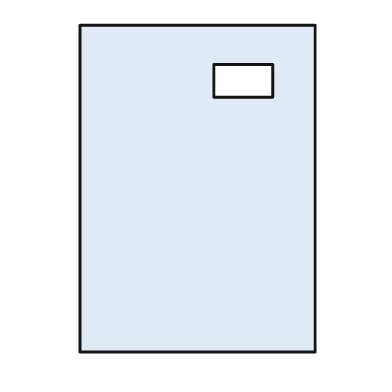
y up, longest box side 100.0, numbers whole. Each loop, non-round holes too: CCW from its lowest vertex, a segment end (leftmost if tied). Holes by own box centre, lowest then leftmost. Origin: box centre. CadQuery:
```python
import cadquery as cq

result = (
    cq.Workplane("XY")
    .moveTo(-36.0, -50.0)
    .lineTo(36.0, -50.0)
    .lineTo(36.0, 50.0)
    .lineTo(-36.0, 50.0)
    .close()
    .moveTo(5.0, 28.0)
    .lineTo(23.0, 28.0)
    .lineTo(23.0, 38.0)
    .lineTo(5.0, 38.0)
    .close()
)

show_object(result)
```